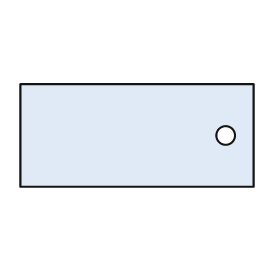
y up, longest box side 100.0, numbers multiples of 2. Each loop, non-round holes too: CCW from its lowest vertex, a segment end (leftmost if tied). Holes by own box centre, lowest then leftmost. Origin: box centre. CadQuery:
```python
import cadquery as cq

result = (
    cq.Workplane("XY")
    .moveTo(-50.0, -22.0)
    .lineTo(50.0, -22.0)
    .lineTo(50.0, 22.0)
    .lineTo(-50.0, 22.0)
    .close()
    .moveTo(38.0, 0.0)
    .circle(4.0)
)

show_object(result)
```